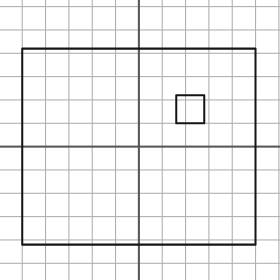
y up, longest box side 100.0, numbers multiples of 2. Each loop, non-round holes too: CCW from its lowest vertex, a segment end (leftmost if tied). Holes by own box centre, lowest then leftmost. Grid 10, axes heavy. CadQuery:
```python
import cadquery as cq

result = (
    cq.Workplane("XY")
    .moveTo(-50.0, -42.0)
    .lineTo(50.0, -42.0)
    .lineTo(50.0, 42.0)
    .lineTo(-50.0, 42.0)
    .close()
    .moveTo(16.0, 10.0)
    .lineTo(28.0, 10.0)
    .lineTo(28.0, 22.0)
    .lineTo(16.0, 22.0)
    .close()
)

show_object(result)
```